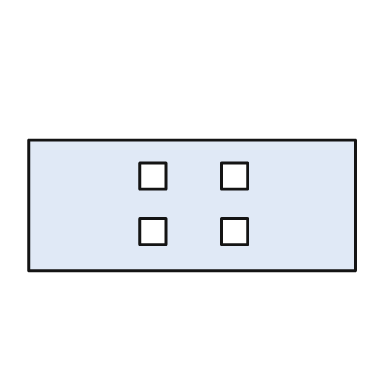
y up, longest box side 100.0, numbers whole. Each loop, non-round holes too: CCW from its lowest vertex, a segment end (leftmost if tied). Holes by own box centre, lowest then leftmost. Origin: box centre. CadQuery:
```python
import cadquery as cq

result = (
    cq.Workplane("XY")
    .moveTo(-50.0, -20.0)
    .lineTo(50.0, -20.0)
    .lineTo(50.0, 20.0)
    .lineTo(-50.0, 20.0)
    .close()
    .moveTo(-16.0, -12.0)
    .lineTo(-8.0, -12.0)
    .lineTo(-8.0, -4.0)
    .lineTo(-16.0, -4.0)
    .close()
    .moveTo(9.0, -12.0)
    .lineTo(17.0, -12.0)
    .lineTo(17.0, -4.0)
    .lineTo(9.0, -4.0)
    .close()
    .moveTo(-16.0, 5.0)
    .lineTo(-8.0, 5.0)
    .lineTo(-8.0, 13.0)
    .lineTo(-16.0, 13.0)
    .close()
    .moveTo(9.0, 5.0)
    .lineTo(17.0, 5.0)
    .lineTo(17.0, 13.0)
    .lineTo(9.0, 13.0)
    .close()
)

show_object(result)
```